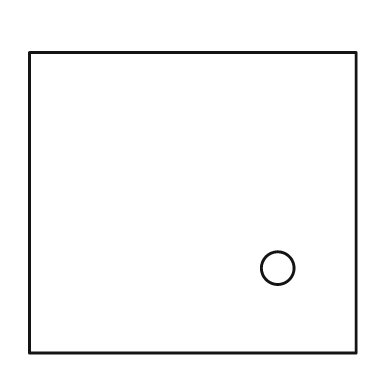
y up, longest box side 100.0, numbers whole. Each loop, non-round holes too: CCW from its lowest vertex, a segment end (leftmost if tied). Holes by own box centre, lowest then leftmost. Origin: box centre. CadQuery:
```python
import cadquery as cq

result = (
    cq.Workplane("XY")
    .moveTo(-50.0, -46.0)
    .lineTo(50.0, -46.0)
    .lineTo(50.0, 46.0)
    .lineTo(-50.0, 46.0)
    .close()
    .moveTo(26.0, -20.0)
    .circle(5.0)
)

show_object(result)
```